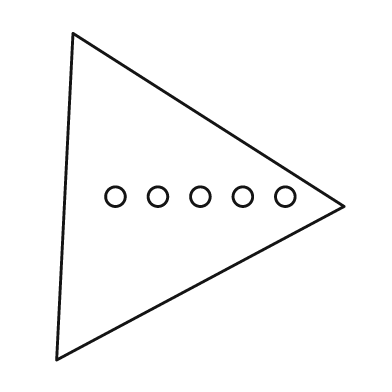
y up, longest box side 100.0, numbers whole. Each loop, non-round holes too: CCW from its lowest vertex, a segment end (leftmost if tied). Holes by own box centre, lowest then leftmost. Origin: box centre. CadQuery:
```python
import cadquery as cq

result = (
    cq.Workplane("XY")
    .moveTo(-44.0, -50.0)
    .lineTo(44.0, -3.0)
    .lineTo(-39.0, 50.0)
    .close()
    .moveTo(-26.0, 0.0)
    .circle(3.0)
    .moveTo(-13.0, 0.0)
    .circle(3.0)
    .moveTo(0.0, 0.0)
    .circle(3.0)
    .moveTo(13.0, 0.0)
    .circle(3.0)
    .moveTo(26.0, 0.0)
    .circle(3.0)
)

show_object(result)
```